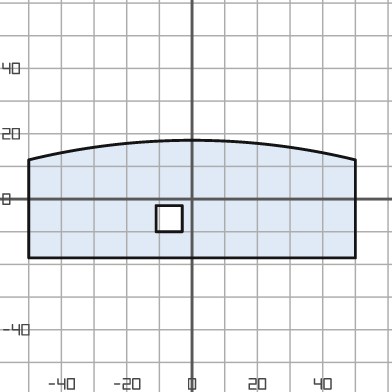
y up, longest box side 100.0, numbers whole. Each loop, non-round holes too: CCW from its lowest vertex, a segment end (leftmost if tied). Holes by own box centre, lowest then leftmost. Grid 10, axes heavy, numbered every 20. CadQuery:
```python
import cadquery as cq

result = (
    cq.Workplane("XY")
    .moveTo(-50.0, -18.0)
    .lineTo(50.0, -18.0)
    .lineTo(50.0, 12.0)
    .threePointArc((0.0, 18.0), (-50.0, 12.0))
    .close()
    .moveTo(-11.0, -10.0)
    .lineTo(-3.0, -10.0)
    .lineTo(-3.0, -2.0)
    .lineTo(-11.0, -2.0)
    .close()
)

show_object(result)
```